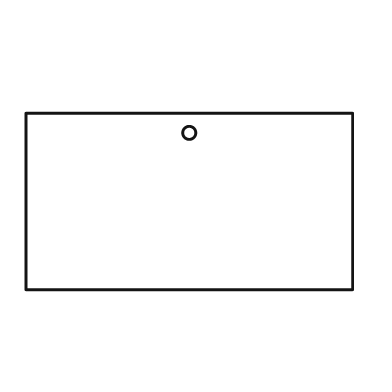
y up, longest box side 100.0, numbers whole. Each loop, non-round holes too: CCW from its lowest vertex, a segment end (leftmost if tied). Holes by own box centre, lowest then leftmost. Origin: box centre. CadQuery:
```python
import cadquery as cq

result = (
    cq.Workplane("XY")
    .moveTo(-50.0, -27.0)
    .lineTo(50.0, -27.0)
    .lineTo(50.0, 27.0)
    .lineTo(-50.0, 27.0)
    .close()
    .moveTo(0.0, 21.0)
    .circle(2.0)
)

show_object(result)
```